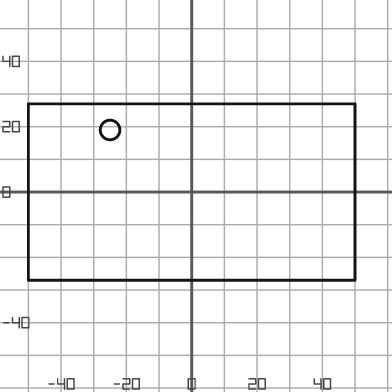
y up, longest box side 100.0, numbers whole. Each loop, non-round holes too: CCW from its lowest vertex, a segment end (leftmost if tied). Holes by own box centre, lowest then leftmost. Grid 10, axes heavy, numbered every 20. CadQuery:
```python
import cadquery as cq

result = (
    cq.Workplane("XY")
    .moveTo(-50.0, -27.0)
    .lineTo(50.0, -27.0)
    .lineTo(50.0, 27.0)
    .lineTo(-50.0, 27.0)
    .close()
    .moveTo(-25.0, 19.0)
    .circle(3.0)
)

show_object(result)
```